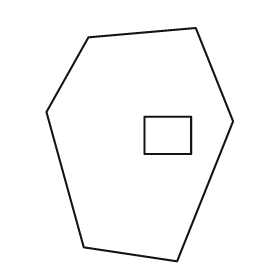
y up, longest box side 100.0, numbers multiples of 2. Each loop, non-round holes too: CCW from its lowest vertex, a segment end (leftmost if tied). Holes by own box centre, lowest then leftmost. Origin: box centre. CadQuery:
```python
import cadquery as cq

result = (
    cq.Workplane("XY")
    .moveTo(16.0, -50.0)
    .lineTo(40.0, 10.0)
    .lineTo(24.0, 50.0)
    .lineTo(-22.0, 46.0)
    .lineTo(-40.0, 14.0)
    .lineTo(-24.0, -44.0)
    .close()
    .moveTo(2.0, -4.0)
    .lineTo(22.0, -4.0)
    .lineTo(22.0, 12.0)
    .lineTo(2.0, 12.0)
    .close()
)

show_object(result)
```